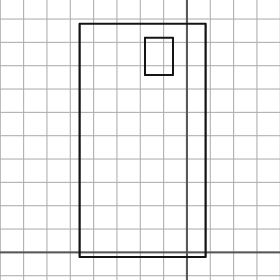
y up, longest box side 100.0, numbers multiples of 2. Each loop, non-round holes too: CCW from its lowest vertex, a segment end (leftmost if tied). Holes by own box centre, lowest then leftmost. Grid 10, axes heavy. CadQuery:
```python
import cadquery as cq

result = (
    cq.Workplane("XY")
    .moveTo(-46.0, -2.0)
    .lineTo(8.0, -2.0)
    .lineTo(8.0, 98.0)
    .lineTo(-46.0, 98.0)
    .close()
    .moveTo(-18.0, 76.0)
    .lineTo(-6.0, 76.0)
    .lineTo(-6.0, 92.0)
    .lineTo(-18.0, 92.0)
    .close()
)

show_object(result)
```